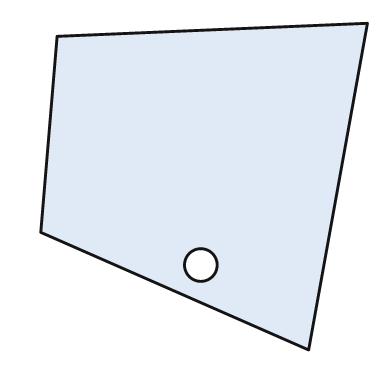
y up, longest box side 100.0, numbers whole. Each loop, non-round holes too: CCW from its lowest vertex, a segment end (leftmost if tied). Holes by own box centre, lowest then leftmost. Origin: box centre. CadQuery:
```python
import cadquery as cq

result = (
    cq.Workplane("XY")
    .moveTo(32.0, -50.0)
    .lineTo(50.0, 50.0)
    .lineTo(-45.0, 46.0)
    .lineTo(-50.0, -14.0)
    .close()
    .moveTo(-1.0, -24.0)
    .circle(5.0)
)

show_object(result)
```